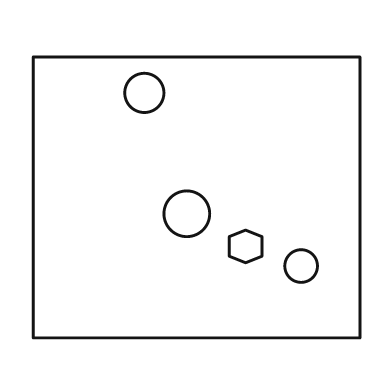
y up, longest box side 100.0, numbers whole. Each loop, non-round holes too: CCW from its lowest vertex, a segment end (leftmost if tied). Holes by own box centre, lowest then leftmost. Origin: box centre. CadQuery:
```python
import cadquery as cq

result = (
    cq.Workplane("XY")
    .moveTo(-50.0, -43.0)
    .lineTo(50.0, -43.0)
    .lineTo(50.0, 43.0)
    .lineTo(-50.0, 43.0)
    .close()
    .moveTo(32.0, -21.0)
    .circle(5.0)
    .moveTo(15.0, -20.0)
    .lineTo(20.0, -18.0)
    .lineTo(20.0, -12.0)
    .lineTo(15.0, -10.0)
    .lineTo(10.0, -12.0)
    .lineTo(10.0, -18.0)
    .close()
    .moveTo(-3.0, -5.0)
    .circle(7.0)
    .moveTo(-16.0, 32.0)
    .circle(6.0)
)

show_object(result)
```